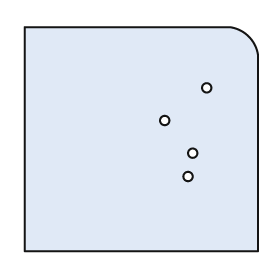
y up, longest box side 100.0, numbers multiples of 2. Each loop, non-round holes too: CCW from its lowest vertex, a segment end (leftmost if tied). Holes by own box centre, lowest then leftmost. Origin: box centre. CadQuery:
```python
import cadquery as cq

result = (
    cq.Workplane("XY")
    .moveTo(-50.0, -48.0)
    .lineTo(50.0, -48.0)
    .lineTo(50.0, 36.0)
    .threePointArc((46.0, 44.0), (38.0, 48.0))
    .lineTo(-50.0, 48.0)
    .close()
    .moveTo(20.0, -16.0)
    .circle(2.0)
    .moveTo(22.0, -6.0)
    .circle(2.0)
    .moveTo(10.0, 8.0)
    .circle(2.0)
    .moveTo(28.0, 22.0)
    .circle(2.0)
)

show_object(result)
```